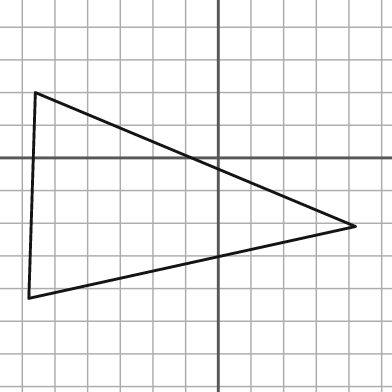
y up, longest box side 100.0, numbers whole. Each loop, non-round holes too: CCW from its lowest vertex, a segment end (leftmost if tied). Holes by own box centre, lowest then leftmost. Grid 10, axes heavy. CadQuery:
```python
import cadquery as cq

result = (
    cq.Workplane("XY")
    .moveTo(-58.0, -43.0)
    .lineTo(42.0, -21.0)
    .lineTo(-56.0, 20.0)
    .close()
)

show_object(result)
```